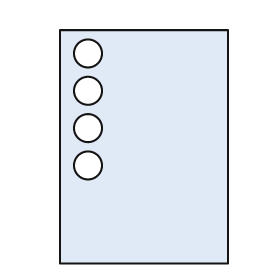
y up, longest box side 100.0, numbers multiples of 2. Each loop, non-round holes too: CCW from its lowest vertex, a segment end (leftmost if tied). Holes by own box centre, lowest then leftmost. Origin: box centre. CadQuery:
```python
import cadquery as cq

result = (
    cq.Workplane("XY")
    .moveTo(-36.0, -50.0)
    .lineTo(36.0, -50.0)
    .lineTo(36.0, 50.0)
    .lineTo(-36.0, 50.0)
    .close()
    .moveTo(-24.0, -8.0)
    .circle(6.0)
    .moveTo(-24.0, 8.0)
    .circle(6.0)
    .moveTo(-24.0, 24.0)
    .circle(6.0)
    .moveTo(-24.0, 40.0)
    .circle(6.0)
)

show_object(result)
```